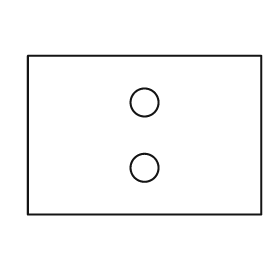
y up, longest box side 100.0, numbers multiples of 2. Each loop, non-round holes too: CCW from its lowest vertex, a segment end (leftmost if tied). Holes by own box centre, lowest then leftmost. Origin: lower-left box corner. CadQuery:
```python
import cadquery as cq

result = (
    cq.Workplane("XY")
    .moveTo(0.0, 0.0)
    .lineTo(100.0, 0.0)
    .lineTo(100.0, 68.0)
    .lineTo(0.0, 68.0)
    .close()
    .moveTo(50.0, 20.0)
    .circle(6.0)
    .moveTo(50.0, 48.0)
    .circle(6.0)
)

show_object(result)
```